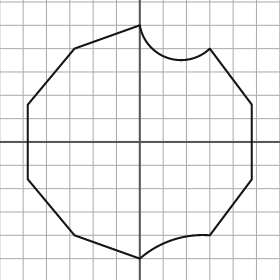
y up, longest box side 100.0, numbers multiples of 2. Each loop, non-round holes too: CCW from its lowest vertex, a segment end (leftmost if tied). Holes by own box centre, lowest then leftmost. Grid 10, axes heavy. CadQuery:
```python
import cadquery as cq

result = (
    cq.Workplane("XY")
    .moveTo(0.0, -50.0)
    .threePointArc((14.0, -42.0), (30.0, -40.0))
    .lineTo(48.0, -16.0)
    .lineTo(48.0, 16.0)
    .lineTo(30.0, 40.0)
    .threePointArc((12.0, 36.0), (0.0, 50.0))
    .lineTo(-28.0, 40.0)
    .lineTo(-48.0, 16.0)
    .lineTo(-48.0, -16.0)
    .lineTo(-28.0, -40.0)
    .close()
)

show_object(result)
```